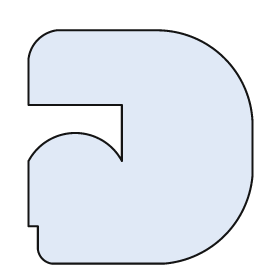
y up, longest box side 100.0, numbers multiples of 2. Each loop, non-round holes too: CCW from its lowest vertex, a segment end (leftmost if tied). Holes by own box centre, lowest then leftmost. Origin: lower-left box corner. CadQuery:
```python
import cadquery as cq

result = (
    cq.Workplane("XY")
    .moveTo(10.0, 0.0)
    .lineTo(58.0, 0.0)
    .threePointArc((84.0, 12.0), (96.0, 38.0))
    .lineTo(96.0, 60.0)
    .threePointArc((84.0, 88.0), (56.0, 100.0))
    .lineTo(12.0, 100.0)
    .threePointArc((4.0, 96.0), (0.0, 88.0))
    .lineTo(0.0, 68.0)
    .lineTo(40.0, 68.0)
    .lineTo(40.0, 44.0)
    .threePointArc((20.0, 56.0), (0.0, 44.0))
    .lineTo(0.0, 16.0)
    .lineTo(4.0, 16.0)
    .lineTo(4.0, 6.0)
    .threePointArc((6.0, 2.0), (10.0, 0.0))
    .close()
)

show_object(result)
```